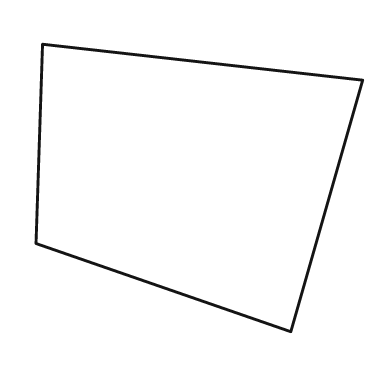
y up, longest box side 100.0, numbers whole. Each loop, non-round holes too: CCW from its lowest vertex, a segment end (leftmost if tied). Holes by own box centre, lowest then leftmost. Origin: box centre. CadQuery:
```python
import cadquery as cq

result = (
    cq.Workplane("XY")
    .moveTo(28.0, -44.0)
    .lineTo(50.0, 33.0)
    .lineTo(-48.0, 44.0)
    .lineTo(-50.0, -17.0)
    .close()
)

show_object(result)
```